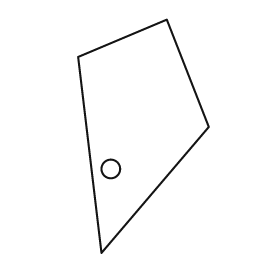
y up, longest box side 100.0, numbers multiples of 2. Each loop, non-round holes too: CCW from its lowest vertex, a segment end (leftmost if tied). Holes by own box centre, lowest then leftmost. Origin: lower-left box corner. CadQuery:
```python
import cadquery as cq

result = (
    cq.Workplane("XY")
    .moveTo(10.0, 0.0)
    .lineTo(56.0, 54.0)
    .lineTo(38.0, 100.0)
    .lineTo(0.0, 84.0)
    .close()
    .moveTo(14.0, 36.0)
    .circle(4.0)
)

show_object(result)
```